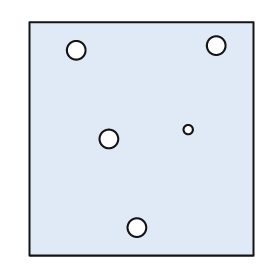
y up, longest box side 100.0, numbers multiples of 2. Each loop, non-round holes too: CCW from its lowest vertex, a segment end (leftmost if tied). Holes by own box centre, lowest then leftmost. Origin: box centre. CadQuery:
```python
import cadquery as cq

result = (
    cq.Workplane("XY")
    .moveTo(-48.0, -50.0)
    .lineTo(48.0, -50.0)
    .lineTo(48.0, 50.0)
    .lineTo(-48.0, 50.0)
    .close()
    .moveTo(-2.0, -38.0)
    .circle(4.0)
    .moveTo(-14.0, 0.0)
    .circle(4.0)
    .moveTo(20.0, 4.0)
    .circle(2.0)
    .moveTo(-28.0, 38.0)
    .circle(4.0)
    .moveTo(32.0, 40.0)
    .circle(4.0)
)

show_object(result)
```